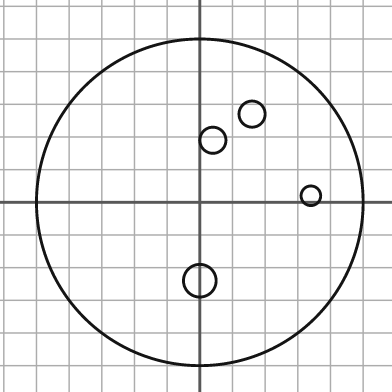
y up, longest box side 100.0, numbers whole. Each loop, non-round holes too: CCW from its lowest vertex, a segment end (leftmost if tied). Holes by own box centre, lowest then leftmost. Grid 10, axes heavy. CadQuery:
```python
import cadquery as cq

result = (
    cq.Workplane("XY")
    .moveTo(0.0, 0.0)
    .circle(50.0)
    .moveTo(0.0, -24.0)
    .circle(5.0)
    .moveTo(34.0, 2.0)
    .circle(3.0)
    .moveTo(4.0, 19.0)
    .circle(4.0)
    .moveTo(16.0, 27.0)
    .circle(4.0)
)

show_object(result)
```